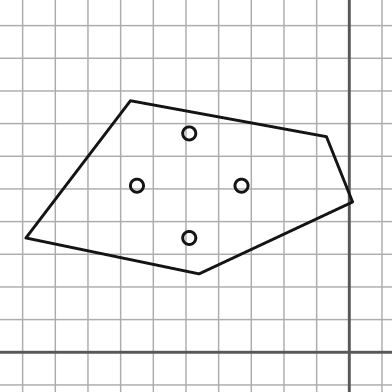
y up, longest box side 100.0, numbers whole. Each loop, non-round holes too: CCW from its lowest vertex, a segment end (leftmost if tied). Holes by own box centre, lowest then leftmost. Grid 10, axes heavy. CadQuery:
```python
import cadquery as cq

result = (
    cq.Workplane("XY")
    .moveTo(-46.0, 24.0)
    .lineTo(1.0, 46.0)
    .lineTo(-7.0, 66.0)
    .lineTo(-67.0, 77.0)
    .lineTo(-99.0, 35.0)
    .close()
    .moveTo(-49.0, 35.0)
    .circle(2.0)
    .moveTo(-65.0, 51.0)
    .circle(2.0)
    .moveTo(-33.0, 51.0)
    .circle(2.0)
    .moveTo(-49.0, 67.0)
    .circle(2.0)
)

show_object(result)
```